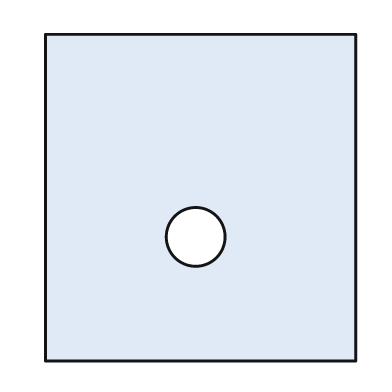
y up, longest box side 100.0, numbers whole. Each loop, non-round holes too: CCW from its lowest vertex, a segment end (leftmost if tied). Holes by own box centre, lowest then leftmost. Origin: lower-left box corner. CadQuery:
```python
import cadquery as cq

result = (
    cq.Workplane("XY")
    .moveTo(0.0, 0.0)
    .lineTo(95.0, 0.0)
    .lineTo(95.0, 100.0)
    .lineTo(0.0, 100.0)
    .close()
    .moveTo(46.0, 38.0)
    .circle(9.0)
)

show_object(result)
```